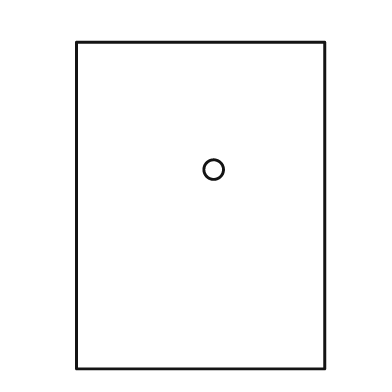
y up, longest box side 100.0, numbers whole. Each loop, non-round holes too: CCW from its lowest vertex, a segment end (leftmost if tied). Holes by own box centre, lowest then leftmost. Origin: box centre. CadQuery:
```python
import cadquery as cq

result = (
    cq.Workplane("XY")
    .moveTo(-38.0, -50.0)
    .lineTo(38.0, -50.0)
    .lineTo(38.0, 50.0)
    .lineTo(-38.0, 50.0)
    .close()
    .moveTo(4.0, 11.0)
    .circle(3.0)
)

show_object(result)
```